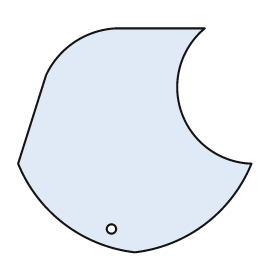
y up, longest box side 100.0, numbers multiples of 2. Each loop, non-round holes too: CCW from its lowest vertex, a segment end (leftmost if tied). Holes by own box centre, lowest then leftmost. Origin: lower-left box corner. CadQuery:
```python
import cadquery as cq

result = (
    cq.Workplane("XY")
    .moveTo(50.0, 0.0)
    .threePointArc((80.0, 12.0), (100.0, 38.0))
    .threePointArc((70.0, 60.0), (80.0, 96.0))
    .lineTo(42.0, 96.0)
    .threePointArc((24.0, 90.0), (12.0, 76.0))
    .lineTo(0.0, 38.0)
    .threePointArc((20.0, 12.0), (50.0, 0.0))
    .close()
    .moveTo(40.0, 10.0)
    .circle(2.0)
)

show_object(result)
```